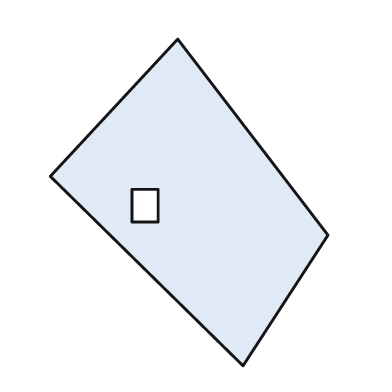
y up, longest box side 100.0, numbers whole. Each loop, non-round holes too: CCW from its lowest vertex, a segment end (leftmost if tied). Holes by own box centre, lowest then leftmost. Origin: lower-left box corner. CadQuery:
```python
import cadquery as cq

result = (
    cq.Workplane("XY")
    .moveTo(59.0, 0.0)
    .lineTo(85.0, 40.0)
    .lineTo(39.0, 100.0)
    .lineTo(0.0, 58.0)
    .close()
    .moveTo(25.0, 44.0)
    .lineTo(33.0, 44.0)
    .lineTo(33.0, 54.0)
    .lineTo(25.0, 54.0)
    .close()
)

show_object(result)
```